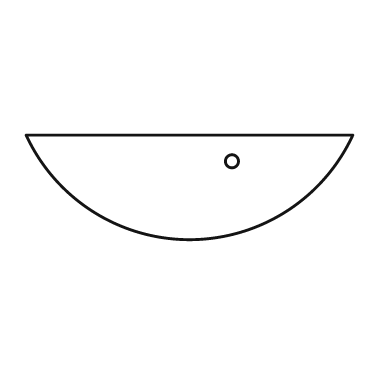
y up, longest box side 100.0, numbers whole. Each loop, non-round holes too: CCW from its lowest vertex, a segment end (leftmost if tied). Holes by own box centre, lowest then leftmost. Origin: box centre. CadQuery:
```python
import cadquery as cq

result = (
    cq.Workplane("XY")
    .moveTo(-50.0, 16.0)
    .threePointArc((0.0, -16.0), (50.0, 16.0))
    .close()
    .moveTo(13.0, 8.0)
    .circle(2.0)
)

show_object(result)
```